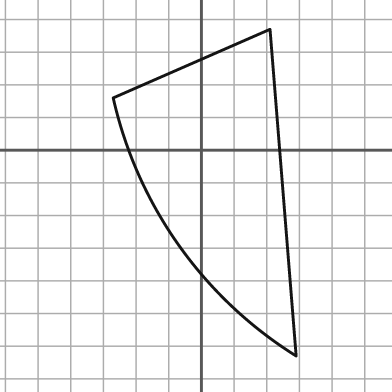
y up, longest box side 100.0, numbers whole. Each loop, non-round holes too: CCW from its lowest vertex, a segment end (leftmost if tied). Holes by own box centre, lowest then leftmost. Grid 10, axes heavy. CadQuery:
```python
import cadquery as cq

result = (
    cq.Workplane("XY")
    .moveTo(29.0, -63.0)
    .lineTo(21.0, 37.0)
    .lineTo(-27.0, 16.0)
    .threePointArc((-7.0, -29.0), (29.0, -63.0))
    .close()
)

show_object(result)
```